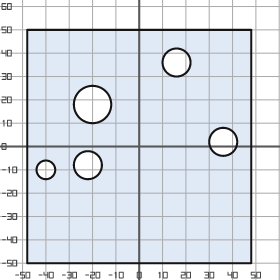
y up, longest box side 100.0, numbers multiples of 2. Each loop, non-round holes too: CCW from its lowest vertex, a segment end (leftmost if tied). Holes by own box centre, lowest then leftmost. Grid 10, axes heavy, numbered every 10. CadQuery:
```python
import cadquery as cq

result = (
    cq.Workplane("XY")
    .moveTo(-48.0, -50.0)
    .lineTo(48.0, -50.0)
    .lineTo(48.0, 50.0)
    .lineTo(-48.0, 50.0)
    .close()
    .moveTo(-40.0, -10.0)
    .circle(4.0)
    .moveTo(-22.0, -8.0)
    .circle(6.0)
    .moveTo(36.0, 2.0)
    .circle(6.0)
    .moveTo(-20.0, 18.0)
    .circle(8.0)
    .moveTo(16.0, 36.0)
    .circle(6.0)
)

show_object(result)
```